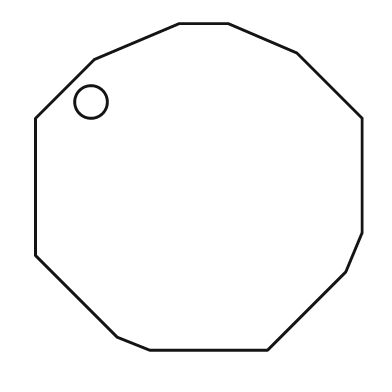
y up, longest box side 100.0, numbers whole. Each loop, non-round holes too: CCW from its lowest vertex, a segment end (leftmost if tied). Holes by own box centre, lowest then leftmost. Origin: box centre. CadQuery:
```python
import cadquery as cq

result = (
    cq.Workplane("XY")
    .moveTo(-15.0, -50.0)
    .lineTo(21.0, -50.0)
    .lineTo(45.0, -26.0)
    .lineTo(50.0, -14.0)
    .lineTo(50.0, 21.0)
    .lineTo(30.0, 41.0)
    .lineTo(9.0, 50.0)
    .lineTo(-6.0, 50.0)
    .lineTo(-32.0, 39.0)
    .lineTo(-50.0, 21.0)
    .lineTo(-50.0, -21.0)
    .lineTo(-25.0, -46.0)
    .close()
    .moveTo(-33.0, 26.0)
    .circle(5.0)
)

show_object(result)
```